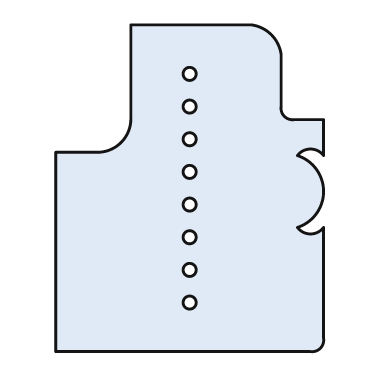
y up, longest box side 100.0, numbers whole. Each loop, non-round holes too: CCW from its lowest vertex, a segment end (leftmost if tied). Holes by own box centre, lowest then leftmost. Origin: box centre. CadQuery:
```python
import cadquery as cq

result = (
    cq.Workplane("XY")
    .moveTo(-41.0, -50.0)
    .lineTo(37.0, -50.0)
    .threePointArc((40.0, -49.0), (41.0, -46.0))
    .lineTo(41.0, -12.0)
    .threePointArc((37.0, -14.0), (33.0, -12.0))
    .threePointArc((41.0, -1.0), (33.0, 10.0))
    .threePointArc((37.0, 12.0), (41.0, 10.0))
    .lineTo(41.0, 21.0)
    .lineTo(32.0, 21.0)
    .threePointArc((29.0, 22.0), (28.0, 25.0))
    .lineTo(28.0, 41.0)
    .threePointArc((25.0, 47.0), (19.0, 50.0))
    .lineTo(-18.0, 50.0)
    .lineTo(-18.0, 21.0)
    .threePointArc((-21.0, 14.0), (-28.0, 11.0))
    .lineTo(-41.0, 11.0)
    .close()
    .moveTo(0.0, -35.0)
    .circle(2.0)
    .moveTo(0.0, -25.0)
    .circle(2.0)
    .moveTo(0.0, -15.0)
    .circle(2.0)
    .moveTo(0.0, -5.0)
    .circle(2.0)
    .moveTo(0.0, 5.0)
    .circle(2.0)
    .moveTo(0.0, 15.0)
    .circle(2.0)
    .moveTo(0.0, 25.0)
    .circle(2.0)
    .moveTo(0.0, 35.0)
    .circle(2.0)
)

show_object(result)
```